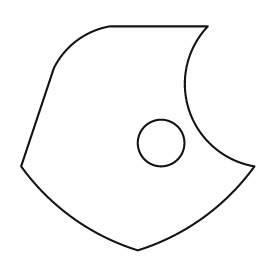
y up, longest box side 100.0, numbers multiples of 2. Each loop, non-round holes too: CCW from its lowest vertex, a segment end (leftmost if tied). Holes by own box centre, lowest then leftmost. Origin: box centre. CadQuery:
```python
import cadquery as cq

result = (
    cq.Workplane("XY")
    .moveTo(0.0, -48.0)
    .threePointArc((28.0, -34.0), (50.0, -12.0))
    .threePointArc((22.0, 12.0), (30.0, 48.0))
    .lineTo(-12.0, 48.0)
    .threePointArc((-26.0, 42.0), (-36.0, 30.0))
    .lineTo(-50.0, -12.0)
    .threePointArc((-28.0, -34.0), (0.0, -48.0))
    .close()
    .moveTo(10.0, -2.0)
    .circle(10.0)
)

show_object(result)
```